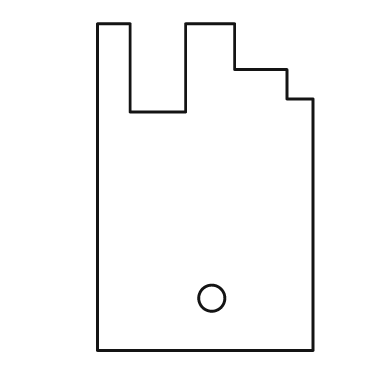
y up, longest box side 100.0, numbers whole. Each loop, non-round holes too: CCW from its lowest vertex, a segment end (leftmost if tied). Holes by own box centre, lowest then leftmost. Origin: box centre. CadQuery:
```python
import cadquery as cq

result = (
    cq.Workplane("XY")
    .moveTo(-33.0, -50.0)
    .lineTo(33.0, -50.0)
    .lineTo(33.0, 27.0)
    .lineTo(25.0, 27.0)
    .lineTo(25.0, 36.0)
    .lineTo(9.0, 36.0)
    .lineTo(9.0, 50.0)
    .lineTo(-6.0, 50.0)
    .lineTo(-6.0, 23.0)
    .lineTo(-23.0, 23.0)
    .lineTo(-23.0, 50.0)
    .lineTo(-33.0, 50.0)
    .close()
    .moveTo(2.0, -34.0)
    .circle(4.0)
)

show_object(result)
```